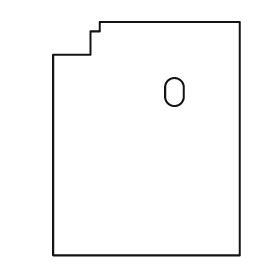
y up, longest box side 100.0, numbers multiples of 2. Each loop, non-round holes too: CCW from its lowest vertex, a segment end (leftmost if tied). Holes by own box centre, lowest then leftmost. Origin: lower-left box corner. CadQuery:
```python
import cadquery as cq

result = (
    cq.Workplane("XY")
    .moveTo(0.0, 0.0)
    .lineTo(80.0, 0.0)
    .lineTo(80.0, 100.0)
    .lineTo(20.0, 100.0)
    .lineTo(20.0, 96.0)
    .lineTo(16.0, 96.0)
    .lineTo(16.0, 86.0)
    .lineTo(0.0, 86.0)
    .close()
    .moveTo(48.0, 68.0)
    .threePointArc((52.0, 64.0), (56.0, 68.0))
    .lineTo(56.0, 72.0)
    .threePointArc((52.0, 76.0), (48.0, 72.0))
    .close()
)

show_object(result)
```